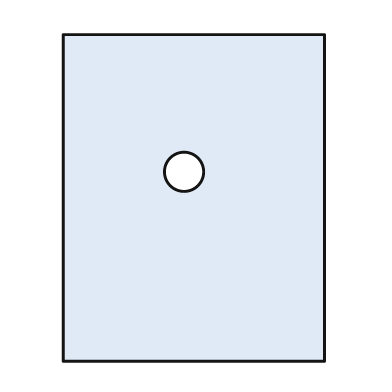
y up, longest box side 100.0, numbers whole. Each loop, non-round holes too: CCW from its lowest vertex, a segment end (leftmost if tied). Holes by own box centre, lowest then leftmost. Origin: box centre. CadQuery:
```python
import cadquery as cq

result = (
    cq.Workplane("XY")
    .moveTo(-40.0, -50.0)
    .lineTo(40.0, -50.0)
    .lineTo(40.0, 50.0)
    .lineTo(-40.0, 50.0)
    .close()
    .moveTo(-3.0, 8.0)
    .circle(6.0)
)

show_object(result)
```